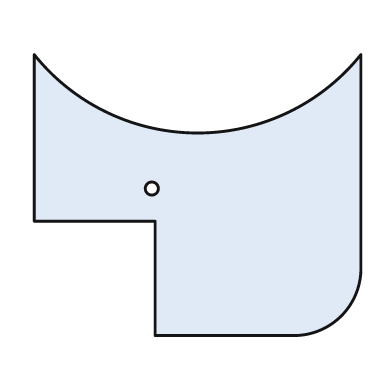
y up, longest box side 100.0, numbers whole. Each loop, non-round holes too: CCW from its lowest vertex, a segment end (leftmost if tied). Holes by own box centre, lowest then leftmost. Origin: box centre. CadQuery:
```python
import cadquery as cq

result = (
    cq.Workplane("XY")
    .moveTo(-13.0, -43.0)
    .lineTo(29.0, -43.0)
    .threePointArc((44.0, -37.0), (50.0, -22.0))
    .lineTo(50.0, 43.0)
    .threePointArc((0.0, 19.0), (-50.0, 43.0))
    .lineTo(-50.0, -8.0)
    .lineTo(-13.0, -8.0)
    .close()
    .moveTo(-14.0, 2.0)
    .circle(2.0)
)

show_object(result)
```